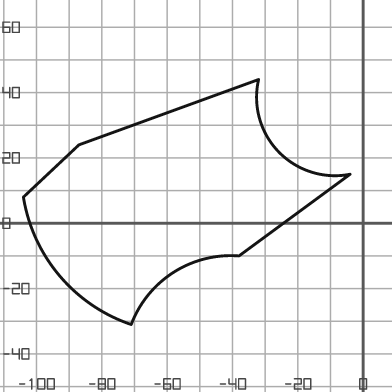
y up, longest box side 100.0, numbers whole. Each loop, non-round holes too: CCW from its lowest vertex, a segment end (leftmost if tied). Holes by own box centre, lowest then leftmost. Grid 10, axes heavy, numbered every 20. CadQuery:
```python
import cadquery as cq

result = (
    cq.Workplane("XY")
    .moveTo(-71.0, -31.0)
    .threePointArc((-58.0, -15.0), (-38.0, -10.0))
    .lineTo(-4.0, 15.0)
    .threePointArc((-26.0, 22.0), (-32.0, 44.0))
    .lineTo(-87.0, 24.0)
    .lineTo(-104.0, 8.0)
    .threePointArc((-93.0, -16.0), (-71.0, -31.0))
    .close()
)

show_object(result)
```